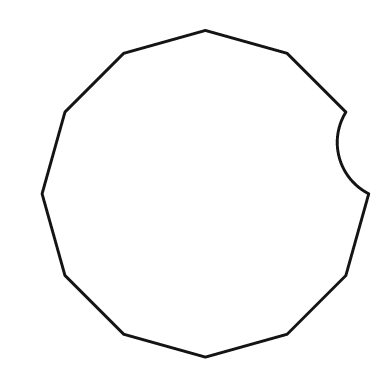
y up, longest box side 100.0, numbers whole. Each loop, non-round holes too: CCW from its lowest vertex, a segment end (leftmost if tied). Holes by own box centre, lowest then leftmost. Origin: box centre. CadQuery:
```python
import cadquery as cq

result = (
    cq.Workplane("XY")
    .moveTo(0.0, -50.0)
    .lineTo(25.0, -43.0)
    .lineTo(43.0, -25.0)
    .lineTo(50.0, 0.0)
    .threePointArc((41.0, 11.0), (43.0, 25.0))
    .lineTo(25.0, 43.0)
    .lineTo(0.0, 50.0)
    .lineTo(-25.0, 43.0)
    .lineTo(-43.0, 25.0)
    .lineTo(-50.0, 0.0)
    .lineTo(-43.0, -25.0)
    .lineTo(-25.0, -43.0)
    .close()
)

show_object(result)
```